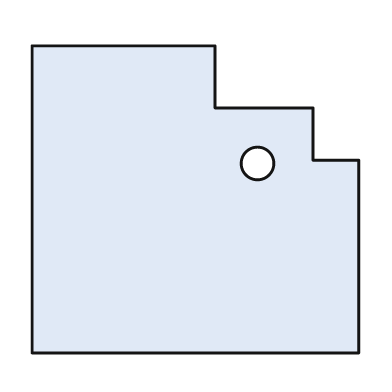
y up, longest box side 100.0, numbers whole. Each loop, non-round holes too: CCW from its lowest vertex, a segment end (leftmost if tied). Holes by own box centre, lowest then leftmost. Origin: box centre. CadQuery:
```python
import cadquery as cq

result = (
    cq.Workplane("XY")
    .moveTo(-50.0, -47.0)
    .lineTo(50.0, -47.0)
    .lineTo(50.0, 12.0)
    .lineTo(36.0, 12.0)
    .lineTo(36.0, 28.0)
    .lineTo(6.0, 28.0)
    .lineTo(6.0, 47.0)
    .lineTo(-50.0, 47.0)
    .close()
    .moveTo(19.0, 11.0)
    .circle(5.0)
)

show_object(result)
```